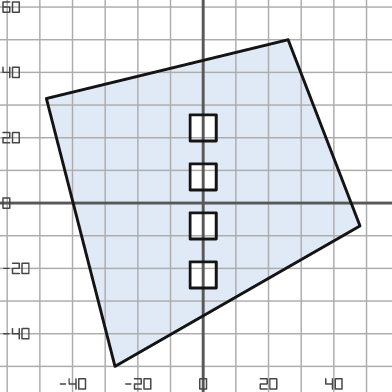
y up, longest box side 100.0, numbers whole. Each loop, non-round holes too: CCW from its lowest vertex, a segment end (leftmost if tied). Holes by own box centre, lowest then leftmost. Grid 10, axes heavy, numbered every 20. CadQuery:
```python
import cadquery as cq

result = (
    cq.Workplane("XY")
    .moveTo(-27.0, -50.0)
    .lineTo(48.0, -7.0)
    .lineTo(26.0, 50.0)
    .lineTo(-48.0, 32.0)
    .close()
    .moveTo(-4.0, -26.0)
    .lineTo(4.0, -26.0)
    .lineTo(4.0, -18.0)
    .lineTo(-4.0, -18.0)
    .close()
    .moveTo(-4.0, -11.0)
    .lineTo(4.0, -11.0)
    .lineTo(4.0, -3.0)
    .lineTo(-4.0, -3.0)
    .close()
    .moveTo(-4.0, 4.0)
    .lineTo(4.0, 4.0)
    .lineTo(4.0, 12.0)
    .lineTo(-4.0, 12.0)
    .close()
    .moveTo(-4.0, 19.0)
    .lineTo(4.0, 19.0)
    .lineTo(4.0, 27.0)
    .lineTo(-4.0, 27.0)
    .close()
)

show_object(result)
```